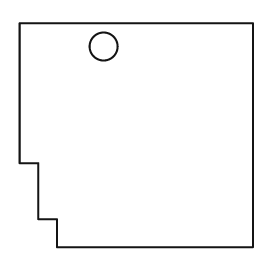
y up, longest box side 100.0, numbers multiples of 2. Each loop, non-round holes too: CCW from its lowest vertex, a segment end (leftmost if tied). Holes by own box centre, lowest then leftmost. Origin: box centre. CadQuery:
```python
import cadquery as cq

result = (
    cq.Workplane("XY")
    .moveTo(-34.0, -48.0)
    .lineTo(50.0, -48.0)
    .lineTo(50.0, 48.0)
    .lineTo(-50.0, 48.0)
    .lineTo(-50.0, -12.0)
    .lineTo(-42.0, -12.0)
    .lineTo(-42.0, -36.0)
    .lineTo(-34.0, -36.0)
    .close()
    .moveTo(-14.0, 38.0)
    .circle(6.0)
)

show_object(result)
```